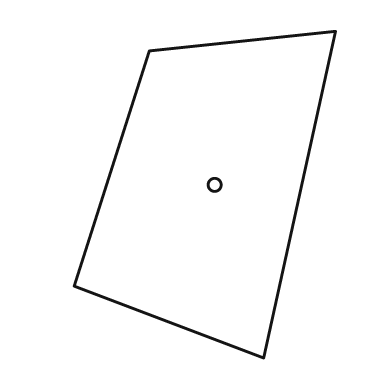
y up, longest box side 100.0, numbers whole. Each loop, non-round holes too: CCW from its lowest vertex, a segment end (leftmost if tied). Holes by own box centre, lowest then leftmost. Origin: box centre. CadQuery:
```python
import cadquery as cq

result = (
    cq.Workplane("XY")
    .moveTo(18.0, -50.0)
    .lineTo(40.0, 50.0)
    .lineTo(-17.0, 44.0)
    .lineTo(-40.0, -28.0)
    .close()
    .moveTo(3.0, 3.0)
    .circle(2.0)
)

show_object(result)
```